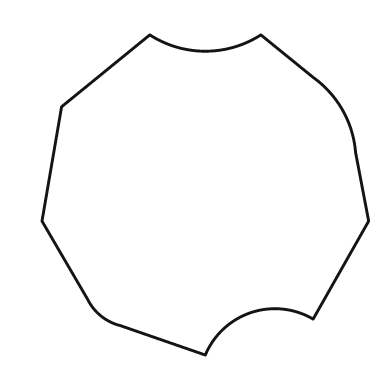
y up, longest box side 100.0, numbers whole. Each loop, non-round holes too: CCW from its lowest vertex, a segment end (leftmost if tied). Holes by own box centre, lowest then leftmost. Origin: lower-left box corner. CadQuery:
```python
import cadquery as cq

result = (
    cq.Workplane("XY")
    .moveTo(50.0, 0.0)
    .threePointArc((64.0, 13.0), (83.0, 11.0))
    .lineTo(100.0, 41.0)
    .lineTo(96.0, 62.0)
    .threePointArc((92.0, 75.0), (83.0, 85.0))
    .lineTo(67.0, 98.0)
    .threePointArc((50.0, 93.0), (33.0, 98.0))
    .lineTo(6.0, 76.0)
    .lineTo(0.0, 41.0)
    .lineTo(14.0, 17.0)
    .threePointArc((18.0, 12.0), (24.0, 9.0))
    .close()
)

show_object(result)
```